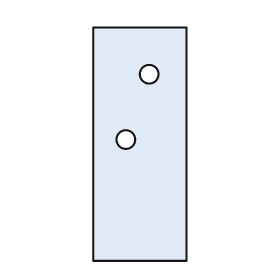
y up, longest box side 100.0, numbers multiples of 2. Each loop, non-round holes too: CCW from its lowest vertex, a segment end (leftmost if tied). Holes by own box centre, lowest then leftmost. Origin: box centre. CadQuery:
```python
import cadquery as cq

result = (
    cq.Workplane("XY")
    .moveTo(-20.0, -50.0)
    .lineTo(20.0, -50.0)
    .lineTo(20.0, 50.0)
    .lineTo(-20.0, 50.0)
    .close()
    .moveTo(-6.0, 2.0)
    .circle(4.0)
    .moveTo(4.0, 30.0)
    .circle(4.0)
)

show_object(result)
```